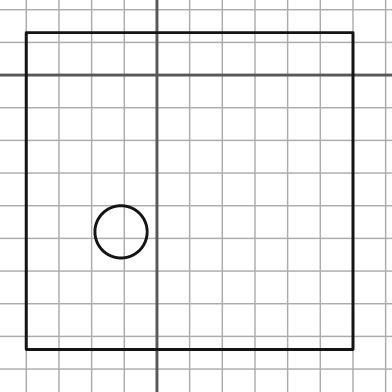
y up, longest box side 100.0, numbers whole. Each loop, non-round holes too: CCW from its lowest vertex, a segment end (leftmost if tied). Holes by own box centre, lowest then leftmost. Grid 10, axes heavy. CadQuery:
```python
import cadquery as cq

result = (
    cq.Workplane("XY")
    .moveTo(-40.0, -84.0)
    .lineTo(60.0, -84.0)
    .lineTo(60.0, 13.0)
    .lineTo(-40.0, 13.0)
    .close()
    .moveTo(-11.0, -48.0)
    .circle(8.0)
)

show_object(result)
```